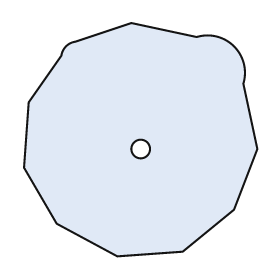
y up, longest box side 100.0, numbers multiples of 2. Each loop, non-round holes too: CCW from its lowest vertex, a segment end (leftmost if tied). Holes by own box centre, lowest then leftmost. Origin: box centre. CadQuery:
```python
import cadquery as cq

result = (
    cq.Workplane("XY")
    .moveTo(-10.0, -50.0)
    .lineTo(18.0, -48.0)
    .lineTo(40.0, -30.0)
    .lineTo(50.0, -4.0)
    .lineTo(44.0, 24.0)
    .threePointArc((40.0, 40.0), (24.0, 44.0))
    .lineTo(-4.0, 50.0)
    .lineTo(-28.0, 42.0)
    .threePointArc((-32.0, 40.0), (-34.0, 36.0))
    .lineTo(-48.0, 16.0)
    .lineTo(-50.0, -12.0)
    .lineTo(-36.0, -36.0)
    .close()
    .moveTo(0.0, -4.0)
    .circle(4.0)
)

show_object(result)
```